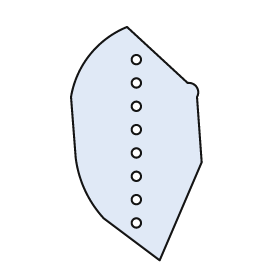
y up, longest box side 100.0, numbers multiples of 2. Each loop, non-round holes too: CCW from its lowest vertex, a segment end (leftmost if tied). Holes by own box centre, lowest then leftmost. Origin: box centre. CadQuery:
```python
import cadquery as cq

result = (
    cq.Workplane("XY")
    .moveTo(10.0, -50.0)
    .lineTo(28.0, -8.0)
    .lineTo(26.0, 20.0)
    .threePointArc((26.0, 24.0), (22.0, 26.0))
    .lineTo(-4.0, 50.0)
    .threePointArc((-20.0, 38.0), (-28.0, 20.0))
    .lineTo(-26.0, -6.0)
    .threePointArc((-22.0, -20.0), (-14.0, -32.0))
    .close()
    .moveTo(0.0, -34.0)
    .circle(2.0)
    .moveTo(0.0, -24.0)
    .circle(2.0)
    .moveTo(0.0, -14.0)
    .circle(2.0)
    .moveTo(0.0, -4.0)
    .circle(2.0)
    .moveTo(0.0, 6.0)
    .circle(2.0)
    .moveTo(0.0, 16.0)
    .circle(2.0)
    .moveTo(0.0, 26.0)
    .circle(2.0)
    .moveTo(0.0, 36.0)
    .circle(2.0)
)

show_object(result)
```